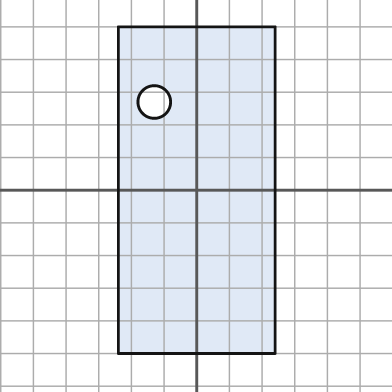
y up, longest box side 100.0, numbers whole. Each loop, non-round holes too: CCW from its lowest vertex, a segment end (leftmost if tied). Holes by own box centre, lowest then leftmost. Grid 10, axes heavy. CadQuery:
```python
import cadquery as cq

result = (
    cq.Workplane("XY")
    .moveTo(-24.0, -50.0)
    .lineTo(24.0, -50.0)
    .lineTo(24.0, 50.0)
    .lineTo(-24.0, 50.0)
    .close()
    .moveTo(-13.0, 27.0)
    .circle(5.0)
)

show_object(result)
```